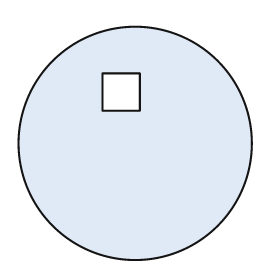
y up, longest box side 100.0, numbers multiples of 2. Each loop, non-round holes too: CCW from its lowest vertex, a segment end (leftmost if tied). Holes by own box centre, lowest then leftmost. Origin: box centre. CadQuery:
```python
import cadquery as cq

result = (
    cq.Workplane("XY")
    .moveTo(0.0, 0.0)
    .circle(50.0)
    .moveTo(-14.0, 14.0)
    .lineTo(2.0, 14.0)
    .lineTo(2.0, 30.0)
    .lineTo(-14.0, 30.0)
    .close()
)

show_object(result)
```